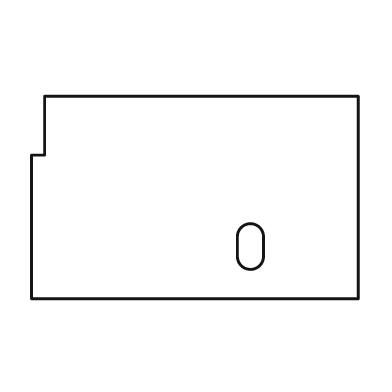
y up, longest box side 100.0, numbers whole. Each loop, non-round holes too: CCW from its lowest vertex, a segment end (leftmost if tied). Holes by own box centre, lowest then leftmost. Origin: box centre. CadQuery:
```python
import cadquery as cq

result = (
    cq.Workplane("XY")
    .moveTo(-50.0, -31.0)
    .lineTo(50.0, -31.0)
    .lineTo(50.0, 31.0)
    .lineTo(-46.0, 31.0)
    .lineTo(-46.0, 13.0)
    .lineTo(-50.0, 13.0)
    .close()
    .moveTo(13.0, -18.0)
    .threePointArc((17.0, -22.0), (21.0, -18.0))
    .lineTo(21.0, -12.0)
    .threePointArc((17.0, -8.0), (13.0, -12.0))
    .close()
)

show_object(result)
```